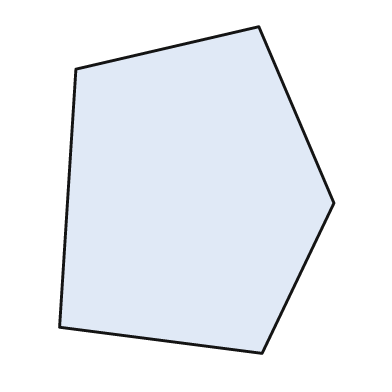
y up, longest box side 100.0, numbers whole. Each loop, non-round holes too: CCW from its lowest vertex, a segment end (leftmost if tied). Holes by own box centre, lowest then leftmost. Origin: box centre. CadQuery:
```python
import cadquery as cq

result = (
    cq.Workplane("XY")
    .moveTo(20.0, -50.0)
    .lineTo(42.0, -4.0)
    .lineTo(19.0, 50.0)
    .lineTo(-37.0, 37.0)
    .lineTo(-42.0, -42.0)
    .close()
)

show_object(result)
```